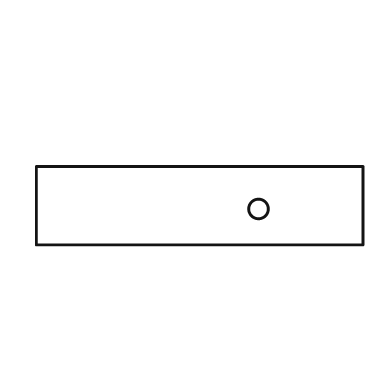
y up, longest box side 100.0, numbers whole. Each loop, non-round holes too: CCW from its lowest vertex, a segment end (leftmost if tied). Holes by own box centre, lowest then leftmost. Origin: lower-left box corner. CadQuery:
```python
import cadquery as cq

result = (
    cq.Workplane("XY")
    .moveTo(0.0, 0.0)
    .lineTo(100.0, 0.0)
    .lineTo(100.0, 24.0)
    .lineTo(0.0, 24.0)
    .close()
    .moveTo(68.0, 11.0)
    .circle(3.0)
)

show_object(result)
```